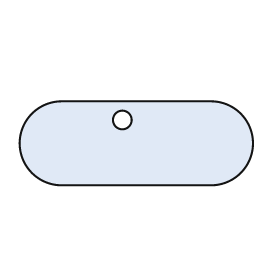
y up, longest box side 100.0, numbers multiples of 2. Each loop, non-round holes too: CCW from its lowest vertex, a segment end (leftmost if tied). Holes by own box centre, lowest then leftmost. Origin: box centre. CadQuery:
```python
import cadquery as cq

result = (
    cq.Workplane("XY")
    .moveTo(-32.0, -18.0)
    .lineTo(32.0, -18.0)
    .threePointArc((50.0, 0.0), (32.0, 18.0))
    .lineTo(-32.0, 18.0)
    .threePointArc((-50.0, 0.0), (-32.0, -18.0))
    .close()
    .moveTo(-6.0, 10.0)
    .circle(4.0)
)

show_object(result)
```